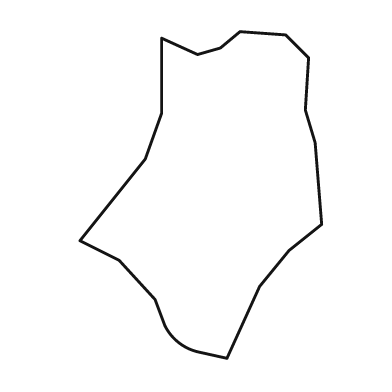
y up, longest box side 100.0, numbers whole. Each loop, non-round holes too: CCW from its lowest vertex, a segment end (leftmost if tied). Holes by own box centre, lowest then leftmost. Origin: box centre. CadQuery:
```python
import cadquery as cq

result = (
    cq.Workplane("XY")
    .moveTo(8.0, -50.0)
    .lineTo(18.0, -28.0)
    .lineTo(27.0, -17.0)
    .lineTo(37.0, -9.0)
    .lineTo(35.0, 16.0)
    .lineTo(32.0, 26.0)
    .lineTo(33.0, 42.0)
    .lineTo(26.0, 49.0)
    .lineTo(12.0, 50.0)
    .lineTo(6.0, 45.0)
    .lineTo(-1.0, 43.0)
    .lineTo(-12.0, 48.0)
    .lineTo(-12.0, 25.0)
    .lineTo(-17.0, 11.0)
    .lineTo(-37.0, -14.0)
    .lineTo(-25.0, -20.0)
    .lineTo(-14.0, -32.0)
    .lineTo(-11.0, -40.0)
    .threePointArc((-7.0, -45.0), (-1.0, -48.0))
    .close()
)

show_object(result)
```